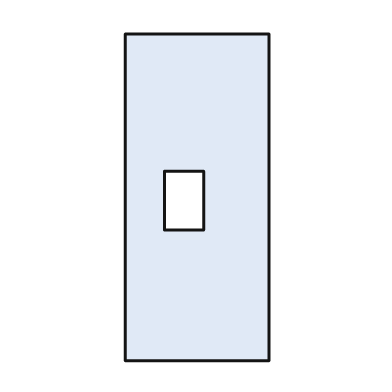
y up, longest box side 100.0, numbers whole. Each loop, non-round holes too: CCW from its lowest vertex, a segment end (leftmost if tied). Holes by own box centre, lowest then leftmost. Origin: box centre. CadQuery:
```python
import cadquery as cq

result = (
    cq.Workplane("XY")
    .moveTo(-22.0, -50.0)
    .lineTo(22.0, -50.0)
    .lineTo(22.0, 50.0)
    .lineTo(-22.0, 50.0)
    .close()
    .moveTo(-10.0, -10.0)
    .lineTo(2.0, -10.0)
    .lineTo(2.0, 8.0)
    .lineTo(-10.0, 8.0)
    .close()
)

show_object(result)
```